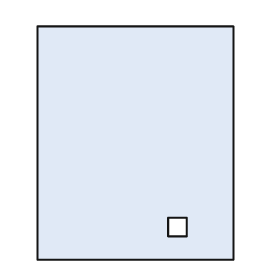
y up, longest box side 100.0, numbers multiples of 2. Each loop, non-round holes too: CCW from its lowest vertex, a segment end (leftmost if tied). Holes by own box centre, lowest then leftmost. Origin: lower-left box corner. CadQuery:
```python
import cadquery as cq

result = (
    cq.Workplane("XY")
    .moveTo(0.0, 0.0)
    .lineTo(84.0, 0.0)
    .lineTo(84.0, 100.0)
    .lineTo(0.0, 100.0)
    .close()
    .moveTo(56.0, 10.0)
    .lineTo(64.0, 10.0)
    .lineTo(64.0, 18.0)
    .lineTo(56.0, 18.0)
    .close()
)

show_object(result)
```